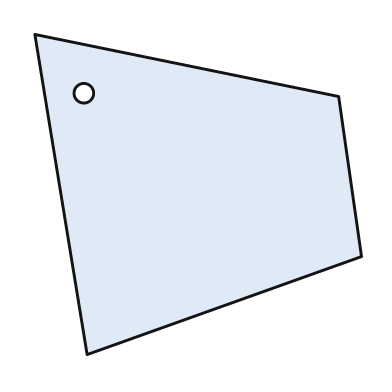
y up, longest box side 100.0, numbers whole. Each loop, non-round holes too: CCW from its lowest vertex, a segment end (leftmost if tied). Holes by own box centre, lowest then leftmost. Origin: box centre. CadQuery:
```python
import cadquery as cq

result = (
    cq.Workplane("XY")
    .moveTo(-34.0, -49.0)
    .lineTo(50.0, -19.0)
    .lineTo(43.0, 30.0)
    .lineTo(-50.0, 49.0)
    .close()
    .moveTo(-35.0, 31.0)
    .circle(3.0)
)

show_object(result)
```